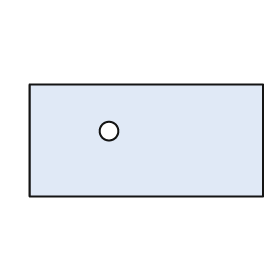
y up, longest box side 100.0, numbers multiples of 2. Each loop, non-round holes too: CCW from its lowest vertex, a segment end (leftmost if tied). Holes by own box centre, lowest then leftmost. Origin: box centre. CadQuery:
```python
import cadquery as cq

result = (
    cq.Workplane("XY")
    .moveTo(-50.0, -24.0)
    .lineTo(50.0, -24.0)
    .lineTo(50.0, 24.0)
    .lineTo(-50.0, 24.0)
    .close()
    .moveTo(-16.0, 4.0)
    .circle(4.0)
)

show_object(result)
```